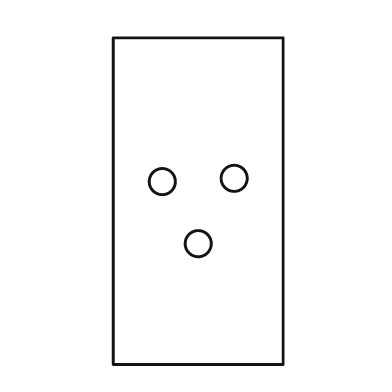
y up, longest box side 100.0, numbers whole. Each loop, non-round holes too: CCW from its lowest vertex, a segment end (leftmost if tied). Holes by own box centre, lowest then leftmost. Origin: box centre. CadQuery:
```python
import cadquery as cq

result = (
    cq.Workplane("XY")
    .moveTo(-26.0, -50.0)
    .lineTo(26.0, -50.0)
    .lineTo(26.0, 50.0)
    .lineTo(-26.0, 50.0)
    .close()
    .moveTo(0.0, -13.0)
    .circle(4.0)
    .moveTo(-11.0, 6.0)
    .circle(4.0)
    .moveTo(11.0, 7.0)
    .circle(4.0)
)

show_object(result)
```